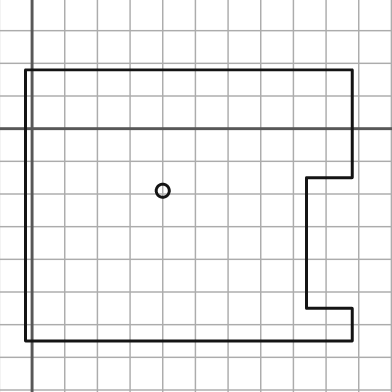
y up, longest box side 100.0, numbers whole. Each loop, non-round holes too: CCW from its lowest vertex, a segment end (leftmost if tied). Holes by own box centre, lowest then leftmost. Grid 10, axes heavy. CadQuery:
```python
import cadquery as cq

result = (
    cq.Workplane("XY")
    .moveTo(-2.0, -65.0)
    .lineTo(98.0, -65.0)
    .lineTo(98.0, -55.0)
    .lineTo(84.0, -55.0)
    .lineTo(84.0, -15.0)
    .lineTo(98.0, -15.0)
    .lineTo(98.0, 18.0)
    .lineTo(-2.0, 18.0)
    .close()
    .moveTo(40.0, -19.0)
    .circle(2.0)
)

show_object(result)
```